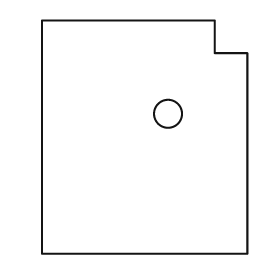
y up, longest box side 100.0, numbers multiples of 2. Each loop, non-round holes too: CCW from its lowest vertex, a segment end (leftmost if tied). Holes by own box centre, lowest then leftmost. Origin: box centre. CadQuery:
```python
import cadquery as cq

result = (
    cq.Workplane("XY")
    .moveTo(-44.0, -50.0)
    .lineTo(44.0, -50.0)
    .lineTo(44.0, 36.0)
    .lineTo(30.0, 36.0)
    .lineTo(30.0, 50.0)
    .lineTo(-44.0, 50.0)
    .close()
    .moveTo(10.0, 10.0)
    .circle(6.0)
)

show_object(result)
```